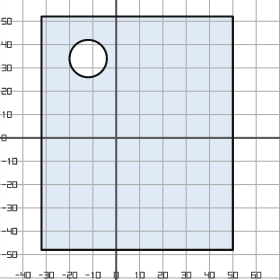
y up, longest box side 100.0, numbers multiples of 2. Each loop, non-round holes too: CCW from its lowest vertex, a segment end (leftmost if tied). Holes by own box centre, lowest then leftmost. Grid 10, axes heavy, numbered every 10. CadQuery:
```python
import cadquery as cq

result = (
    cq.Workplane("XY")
    .moveTo(-32.0, -48.0)
    .lineTo(50.0, -48.0)
    .lineTo(50.0, 52.0)
    .lineTo(-32.0, 52.0)
    .close()
    .moveTo(-12.0, 34.0)
    .circle(8.0)
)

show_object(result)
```